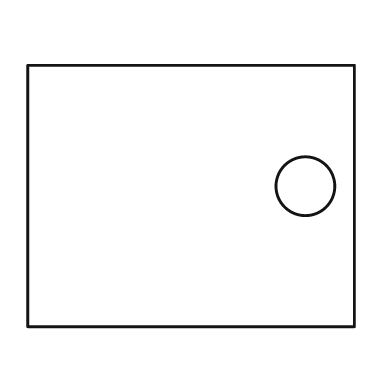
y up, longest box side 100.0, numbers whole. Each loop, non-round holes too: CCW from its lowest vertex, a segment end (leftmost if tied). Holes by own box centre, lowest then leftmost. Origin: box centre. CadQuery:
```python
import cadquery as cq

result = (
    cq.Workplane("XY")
    .moveTo(-50.0, -40.0)
    .lineTo(50.0, -40.0)
    .lineTo(50.0, 40.0)
    .lineTo(-50.0, 40.0)
    .close()
    .moveTo(35.0, 3.0)
    .circle(9.0)
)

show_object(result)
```